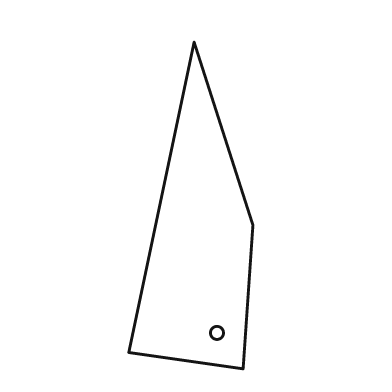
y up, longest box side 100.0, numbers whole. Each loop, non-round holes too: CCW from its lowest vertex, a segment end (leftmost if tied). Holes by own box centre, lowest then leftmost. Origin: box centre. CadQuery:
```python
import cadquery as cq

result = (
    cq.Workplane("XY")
    .moveTo(16.0, -50.0)
    .lineTo(19.0, -6.0)
    .lineTo(1.0, 50.0)
    .lineTo(-19.0, -45.0)
    .close()
    .moveTo(8.0, -39.0)
    .circle(2.0)
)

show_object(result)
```